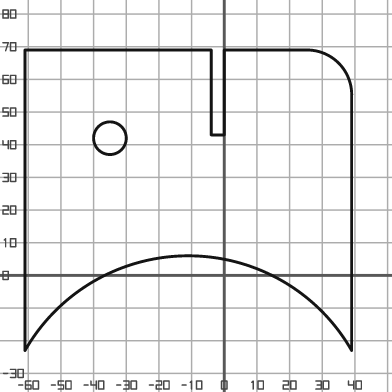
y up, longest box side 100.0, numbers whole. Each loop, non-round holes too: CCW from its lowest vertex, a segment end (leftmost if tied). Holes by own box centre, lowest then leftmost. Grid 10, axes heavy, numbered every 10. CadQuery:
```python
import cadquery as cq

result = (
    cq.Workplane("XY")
    .moveTo(-61.0, -23.0)
    .threePointArc((-11.0, 6.0), (39.0, -23.0))
    .lineTo(39.0, 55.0)
    .threePointArc((35.0, 65.0), (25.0, 69.0))
    .lineTo(0.0, 69.0)
    .lineTo(0.0, 43.0)
    .lineTo(-4.0, 43.0)
    .lineTo(-4.0, 69.0)
    .lineTo(-61.0, 69.0)
    .close()
    .moveTo(-35.0, 42.0)
    .circle(5.0)
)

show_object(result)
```